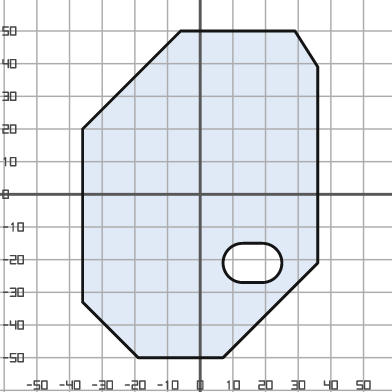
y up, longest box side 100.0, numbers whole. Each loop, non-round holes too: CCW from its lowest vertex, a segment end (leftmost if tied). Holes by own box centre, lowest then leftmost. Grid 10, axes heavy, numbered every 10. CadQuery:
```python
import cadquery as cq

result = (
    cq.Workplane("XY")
    .moveTo(-19.0, -50.0)
    .lineTo(7.0, -50.0)
    .lineTo(36.0, -21.0)
    .lineTo(36.0, 39.0)
    .lineTo(29.0, 50.0)
    .lineTo(-6.0, 50.0)
    .lineTo(-36.0, 20.0)
    .lineTo(-36.0, -33.0)
    .close()
    .moveTo(13.0, -27.0)
    .lineTo(19.0, -27.0)
    .threePointArc((25.0, -21.0), (19.0, -15.0))
    .lineTo(13.0, -15.0)
    .threePointArc((7.0, -21.0), (13.0, -27.0))
    .close()
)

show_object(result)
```